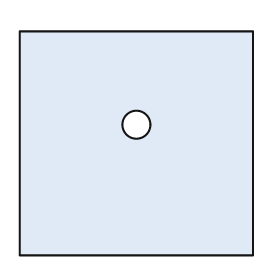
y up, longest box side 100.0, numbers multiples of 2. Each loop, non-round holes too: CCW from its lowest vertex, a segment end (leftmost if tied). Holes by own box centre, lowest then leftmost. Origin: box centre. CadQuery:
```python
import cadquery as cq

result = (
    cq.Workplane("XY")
    .moveTo(-50.0, -48.0)
    .lineTo(50.0, -48.0)
    .lineTo(50.0, 48.0)
    .lineTo(-50.0, 48.0)
    .close()
    .moveTo(0.0, 8.0)
    .circle(6.0)
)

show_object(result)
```